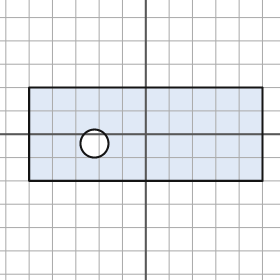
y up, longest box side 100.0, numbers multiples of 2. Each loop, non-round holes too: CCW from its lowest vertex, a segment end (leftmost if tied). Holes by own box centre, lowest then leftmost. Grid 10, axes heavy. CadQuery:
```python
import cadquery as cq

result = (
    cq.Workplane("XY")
    .moveTo(-50.0, -20.0)
    .lineTo(50.0, -20.0)
    .lineTo(50.0, 20.0)
    .lineTo(-50.0, 20.0)
    .close()
    .moveTo(-22.0, -4.0)
    .circle(6.0)
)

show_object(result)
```